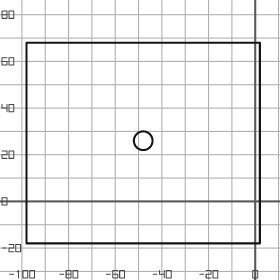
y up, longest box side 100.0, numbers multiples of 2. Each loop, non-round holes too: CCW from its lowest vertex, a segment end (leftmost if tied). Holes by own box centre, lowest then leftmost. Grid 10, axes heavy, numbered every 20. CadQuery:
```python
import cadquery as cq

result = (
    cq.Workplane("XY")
    .moveTo(-98.0, -18.0)
    .lineTo(2.0, -18.0)
    .lineTo(2.0, 68.0)
    .lineTo(-98.0, 68.0)
    .close()
    .moveTo(-48.0, 26.0)
    .circle(4.0)
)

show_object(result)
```